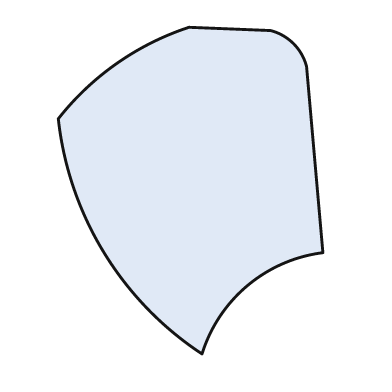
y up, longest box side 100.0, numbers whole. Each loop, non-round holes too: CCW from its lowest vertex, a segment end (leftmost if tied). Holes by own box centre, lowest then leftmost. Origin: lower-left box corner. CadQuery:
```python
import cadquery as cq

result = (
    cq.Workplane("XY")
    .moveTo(44.0, 0.0)
    .threePointArc((58.0, 21.0), (81.0, 31.0))
    .lineTo(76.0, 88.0)
    .threePointArc((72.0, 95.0), (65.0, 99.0))
    .lineTo(40.0, 100.0)
    .threePointArc((18.0, 89.0), (0.0, 72.0))
    .threePointArc((14.0, 31.0), (44.0, 0.0))
    .close()
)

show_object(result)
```